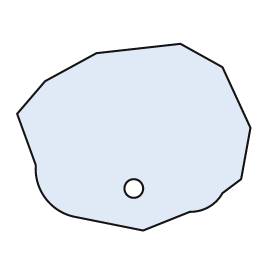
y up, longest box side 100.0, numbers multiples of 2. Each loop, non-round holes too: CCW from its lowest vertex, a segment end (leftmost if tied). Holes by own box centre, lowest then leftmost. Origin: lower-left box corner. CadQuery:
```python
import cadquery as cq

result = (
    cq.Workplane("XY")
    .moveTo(54.0, 0.0)
    .lineTo(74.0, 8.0)
    .threePointArc((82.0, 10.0), (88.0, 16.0))
    .lineTo(96.0, 22.0)
    .lineTo(100.0, 44.0)
    .lineTo(88.0, 70.0)
    .lineTo(70.0, 80.0)
    .lineTo(34.0, 76.0)
    .lineTo(12.0, 64.0)
    .lineTo(0.0, 50.0)
    .lineTo(8.0, 28.0)
    .threePointArc((12.0, 14.0), (24.0, 6.0))
    .close()
    .moveTo(50.0, 18.0)
    .circle(4.0)
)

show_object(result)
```